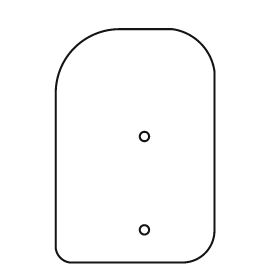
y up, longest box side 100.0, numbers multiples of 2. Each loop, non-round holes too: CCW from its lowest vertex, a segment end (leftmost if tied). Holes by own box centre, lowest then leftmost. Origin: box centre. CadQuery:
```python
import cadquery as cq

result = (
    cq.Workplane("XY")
    .moveTo(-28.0, -50.0)
    .lineTo(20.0, -50.0)
    .threePointArc((30.0, -46.0), (34.0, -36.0))
    .lineTo(34.0, 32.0)
    .threePointArc((28.0, 44.0), (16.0, 50.0))
    .lineTo(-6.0, 50.0)
    .threePointArc((-26.0, 42.0), (-34.0, 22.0))
    .lineTo(-34.0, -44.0)
    .threePointArc((-32.0, -48.0), (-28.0, -50.0))
    .close()
    .moveTo(4.0, -36.0)
    .circle(2.0)
    .moveTo(4.0, 4.0)
    .circle(2.0)
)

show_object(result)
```